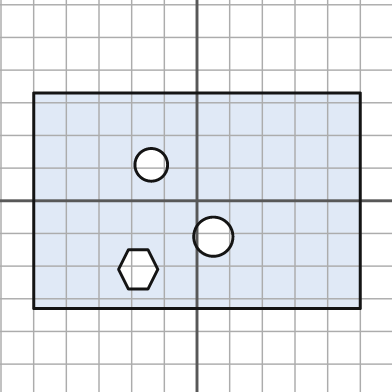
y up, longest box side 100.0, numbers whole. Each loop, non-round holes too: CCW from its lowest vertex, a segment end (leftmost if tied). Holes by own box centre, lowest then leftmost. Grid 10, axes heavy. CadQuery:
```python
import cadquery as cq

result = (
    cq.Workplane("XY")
    .moveTo(-50.0, -33.0)
    .lineTo(50.0, -33.0)
    .lineTo(50.0, 33.0)
    .lineTo(-50.0, 33.0)
    .close()
    .moveTo(-21.0, -27.0)
    .lineTo(-15.0, -27.0)
    .lineTo(-12.0, -21.0)
    .lineTo(-15.0, -15.0)
    .lineTo(-21.0, -15.0)
    .lineTo(-24.0, -21.0)
    .close()
    .moveTo(5.0, -11.0)
    .circle(6.0)
    .moveTo(-14.0, 11.0)
    .circle(5.0)
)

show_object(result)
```